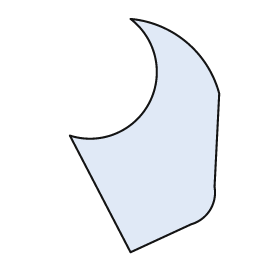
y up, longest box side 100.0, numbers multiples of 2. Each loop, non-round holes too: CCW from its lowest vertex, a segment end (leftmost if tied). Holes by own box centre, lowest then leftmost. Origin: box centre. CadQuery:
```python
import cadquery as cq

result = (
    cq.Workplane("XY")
    .moveTo(-6.0, -50.0)
    .lineTo(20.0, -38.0)
    .threePointArc((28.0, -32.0), (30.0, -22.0))
    .lineTo(32.0, 18.0)
    .threePointArc((18.0, 40.0), (-6.0, 50.0))
    .threePointArc((2.0, 14.0), (-32.0, 0.0))
    .close()
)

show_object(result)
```